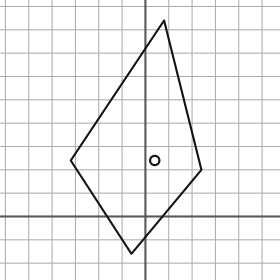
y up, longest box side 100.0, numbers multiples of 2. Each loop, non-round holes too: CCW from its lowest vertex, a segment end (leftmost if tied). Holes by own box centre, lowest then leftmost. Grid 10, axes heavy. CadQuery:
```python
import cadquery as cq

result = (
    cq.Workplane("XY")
    .moveTo(-6.0, -16.0)
    .lineTo(24.0, 20.0)
    .lineTo(8.0, 84.0)
    .lineTo(-32.0, 24.0)
    .close()
    .moveTo(4.0, 24.0)
    .circle(2.0)
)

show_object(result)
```